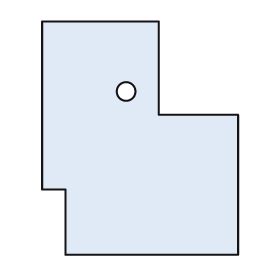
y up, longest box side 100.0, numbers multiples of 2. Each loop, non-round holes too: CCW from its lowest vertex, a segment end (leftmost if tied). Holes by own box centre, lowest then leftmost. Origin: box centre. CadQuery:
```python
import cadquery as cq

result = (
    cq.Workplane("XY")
    .moveTo(-32.0, -50.0)
    .lineTo(42.0, -50.0)
    .lineTo(42.0, 10.0)
    .lineTo(8.0, 10.0)
    .lineTo(8.0, 50.0)
    .lineTo(-42.0, 50.0)
    .lineTo(-42.0, -22.0)
    .lineTo(-32.0, -22.0)
    .close()
    .moveTo(-6.0, 20.0)
    .circle(4.0)
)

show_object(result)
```